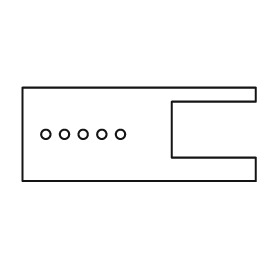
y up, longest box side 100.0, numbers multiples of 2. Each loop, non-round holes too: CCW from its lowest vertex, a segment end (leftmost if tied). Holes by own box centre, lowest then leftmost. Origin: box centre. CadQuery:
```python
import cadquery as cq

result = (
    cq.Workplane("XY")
    .moveTo(-50.0, -20.0)
    .lineTo(50.0, -20.0)
    .lineTo(50.0, -10.0)
    .lineTo(14.0, -10.0)
    .lineTo(14.0, 14.0)
    .lineTo(50.0, 14.0)
    .lineTo(50.0, 20.0)
    .lineTo(-50.0, 20.0)
    .close()
    .moveTo(-40.0, 0.0)
    .circle(2.0)
    .moveTo(-32.0, 0.0)
    .circle(2.0)
    .moveTo(-24.0, 0.0)
    .circle(2.0)
    .moveTo(-16.0, 0.0)
    .circle(2.0)
    .moveTo(-8.0, 0.0)
    .circle(2.0)
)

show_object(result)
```